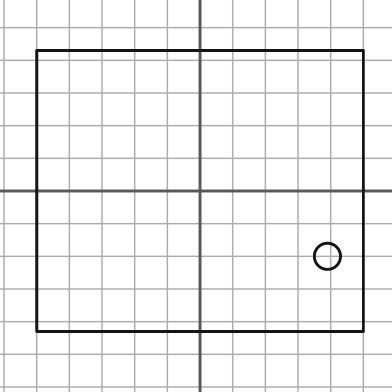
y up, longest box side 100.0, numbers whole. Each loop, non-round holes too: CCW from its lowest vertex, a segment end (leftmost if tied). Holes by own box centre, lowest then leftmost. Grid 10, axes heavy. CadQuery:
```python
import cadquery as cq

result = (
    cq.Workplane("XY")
    .moveTo(-50.0, -43.0)
    .lineTo(50.0, -43.0)
    .lineTo(50.0, 43.0)
    .lineTo(-50.0, 43.0)
    .close()
    .moveTo(39.0, -20.0)
    .circle(4.0)
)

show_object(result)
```